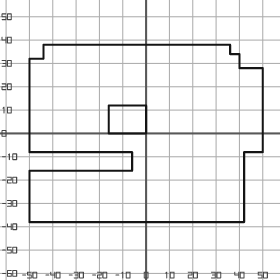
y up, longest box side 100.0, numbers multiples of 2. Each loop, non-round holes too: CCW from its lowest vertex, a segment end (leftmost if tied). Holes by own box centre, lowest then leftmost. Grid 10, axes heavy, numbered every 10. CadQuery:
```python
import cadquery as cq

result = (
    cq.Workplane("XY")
    .moveTo(-50.0, -38.0)
    .lineTo(42.0, -38.0)
    .lineTo(42.0, -8.0)
    .lineTo(50.0, -8.0)
    .lineTo(50.0, 28.0)
    .lineTo(40.0, 28.0)
    .lineTo(40.0, 34.0)
    .lineTo(36.0, 34.0)
    .lineTo(36.0, 38.0)
    .lineTo(-44.0, 38.0)
    .lineTo(-44.0, 32.0)
    .lineTo(-50.0, 32.0)
    .lineTo(-50.0, -8.0)
    .lineTo(-6.0, -8.0)
    .lineTo(-6.0, -16.0)
    .lineTo(-50.0, -16.0)
    .close()
    .moveTo(-16.0, 0.0)
    .lineTo(0.0, 0.0)
    .lineTo(0.0, 12.0)
    .lineTo(-16.0, 12.0)
    .close()
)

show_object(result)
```